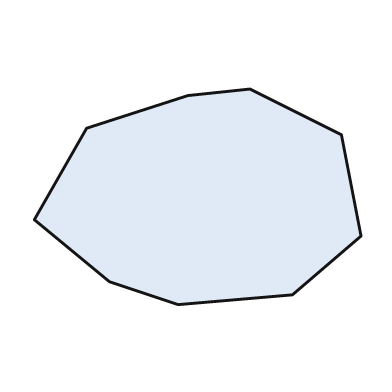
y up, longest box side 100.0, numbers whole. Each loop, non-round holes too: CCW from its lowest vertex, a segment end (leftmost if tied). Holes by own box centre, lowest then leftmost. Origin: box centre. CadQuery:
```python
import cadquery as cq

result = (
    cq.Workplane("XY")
    .moveTo(-6.0, -33.0)
    .lineTo(29.0, -30.0)
    .lineTo(50.0, -12.0)
    .lineTo(44.0, 19.0)
    .lineTo(16.0, 33.0)
    .lineTo(-3.0, 31.0)
    .lineTo(-34.0, 21.0)
    .lineTo(-50.0, -7.0)
    .lineTo(-27.0, -26.0)
    .close()
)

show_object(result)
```